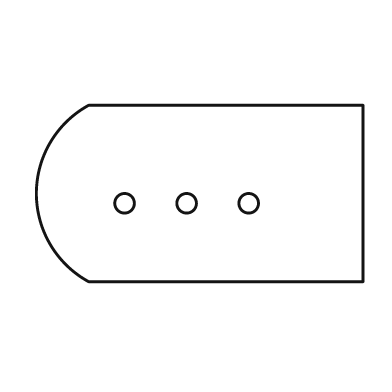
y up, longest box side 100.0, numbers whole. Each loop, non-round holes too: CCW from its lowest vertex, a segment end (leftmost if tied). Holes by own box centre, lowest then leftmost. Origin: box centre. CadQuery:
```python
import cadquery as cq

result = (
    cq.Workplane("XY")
    .moveTo(-34.0, -27.0)
    .lineTo(50.0, -27.0)
    .lineTo(50.0, 27.0)
    .lineTo(-34.0, 27.0)
    .threePointArc((-50.0, 0.0), (-34.0, -27.0))
    .close()
    .moveTo(-23.0, -3.0)
    .circle(3.0)
    .moveTo(-4.0, -3.0)
    .circle(3.0)
    .moveTo(15.0, -3.0)
    .circle(3.0)
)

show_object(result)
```